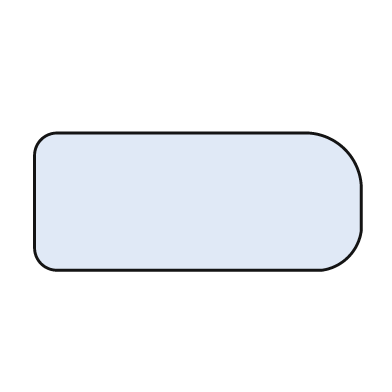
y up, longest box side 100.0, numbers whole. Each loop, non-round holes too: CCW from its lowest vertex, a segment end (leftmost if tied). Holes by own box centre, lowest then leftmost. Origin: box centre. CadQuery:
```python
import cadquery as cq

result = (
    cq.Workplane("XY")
    .moveTo(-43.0, -21.0)
    .lineTo(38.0, -21.0)
    .threePointArc((46.0, -17.0), (50.0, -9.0))
    .lineTo(50.0, 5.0)
    .threePointArc((45.0, 16.0), (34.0, 21.0))
    .lineTo(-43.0, 21.0)
    .threePointArc((-48.0, 19.0), (-50.0, 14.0))
    .lineTo(-50.0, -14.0)
    .threePointArc((-48.0, -19.0), (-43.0, -21.0))
    .close()
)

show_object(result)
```